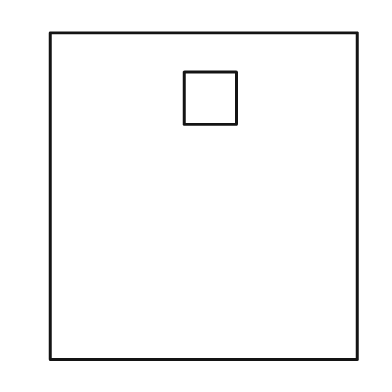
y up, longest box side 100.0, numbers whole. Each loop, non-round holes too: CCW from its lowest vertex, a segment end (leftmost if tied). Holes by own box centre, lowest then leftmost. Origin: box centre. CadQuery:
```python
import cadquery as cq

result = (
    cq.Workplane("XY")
    .moveTo(-47.0, -50.0)
    .lineTo(47.0, -50.0)
    .lineTo(47.0, 50.0)
    .lineTo(-47.0, 50.0)
    .close()
    .moveTo(-6.0, 22.0)
    .lineTo(10.0, 22.0)
    .lineTo(10.0, 38.0)
    .lineTo(-6.0, 38.0)
    .close()
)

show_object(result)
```